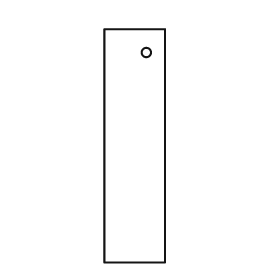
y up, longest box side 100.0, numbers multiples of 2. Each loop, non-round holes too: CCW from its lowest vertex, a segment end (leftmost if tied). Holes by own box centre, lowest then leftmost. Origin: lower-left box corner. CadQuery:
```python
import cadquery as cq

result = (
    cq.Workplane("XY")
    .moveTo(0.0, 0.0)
    .lineTo(26.0, 0.0)
    .lineTo(26.0, 100.0)
    .lineTo(0.0, 100.0)
    .close()
    .moveTo(18.0, 90.0)
    .circle(2.0)
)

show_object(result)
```